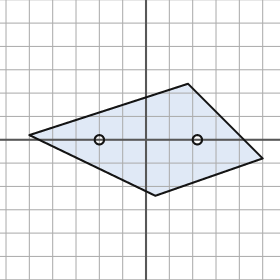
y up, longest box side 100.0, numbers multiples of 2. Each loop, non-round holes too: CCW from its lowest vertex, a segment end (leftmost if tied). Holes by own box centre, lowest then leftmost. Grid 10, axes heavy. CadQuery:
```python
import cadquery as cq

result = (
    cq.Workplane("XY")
    .moveTo(4.0, -24.0)
    .lineTo(50.0, -8.0)
    .lineTo(18.0, 24.0)
    .lineTo(-50.0, 2.0)
    .close()
    .moveTo(-20.0, 0.0)
    .circle(2.0)
    .moveTo(22.0, 0.0)
    .circle(2.0)
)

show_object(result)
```